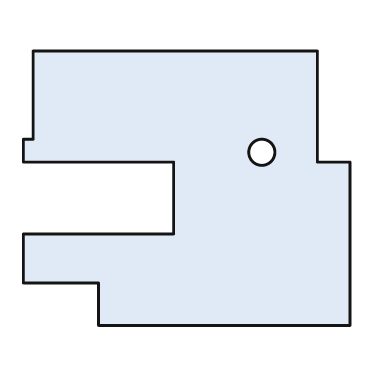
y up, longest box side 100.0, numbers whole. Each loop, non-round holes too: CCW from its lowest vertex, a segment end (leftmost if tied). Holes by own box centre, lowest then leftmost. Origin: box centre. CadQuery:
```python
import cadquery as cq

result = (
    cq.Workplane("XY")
    .moveTo(-27.0, -42.0)
    .lineTo(50.0, -42.0)
    .lineTo(50.0, 8.0)
    .lineTo(40.0, 8.0)
    .lineTo(40.0, 42.0)
    .lineTo(-47.0, 42.0)
    .lineTo(-47.0, 15.0)
    .lineTo(-50.0, 15.0)
    .lineTo(-50.0, 8.0)
    .lineTo(-4.0, 8.0)
    .lineTo(-4.0, -14.0)
    .lineTo(-50.0, -14.0)
    .lineTo(-50.0, -29.0)
    .lineTo(-27.0, -29.0)
    .close()
    .moveTo(23.0, 11.0)
    .circle(4.0)
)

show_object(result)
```